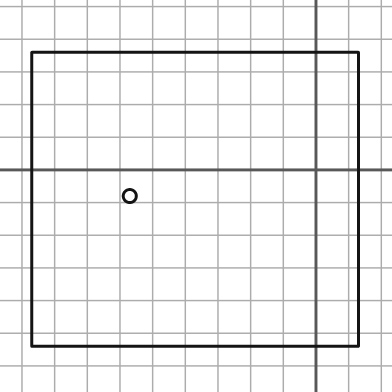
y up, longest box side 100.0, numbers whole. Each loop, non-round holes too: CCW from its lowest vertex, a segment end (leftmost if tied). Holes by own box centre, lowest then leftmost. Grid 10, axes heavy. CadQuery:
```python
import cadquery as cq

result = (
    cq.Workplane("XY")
    .moveTo(-87.0, -54.0)
    .lineTo(13.0, -54.0)
    .lineTo(13.0, 36.0)
    .lineTo(-87.0, 36.0)
    .close()
    .moveTo(-57.0, -8.0)
    .circle(2.0)
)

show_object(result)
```